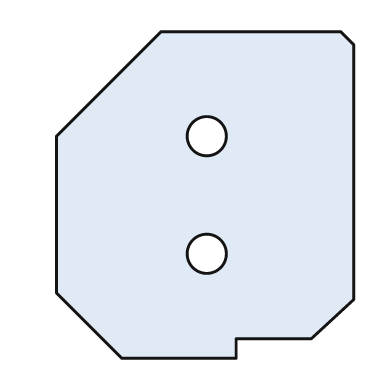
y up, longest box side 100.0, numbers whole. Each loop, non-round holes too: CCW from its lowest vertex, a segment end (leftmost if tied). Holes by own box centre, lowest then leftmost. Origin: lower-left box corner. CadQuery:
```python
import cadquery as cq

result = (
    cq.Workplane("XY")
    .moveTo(20.0, 0.0)
    .lineTo(55.0, 0.0)
    .lineTo(55.0, 6.0)
    .lineTo(78.0, 6.0)
    .lineTo(91.0, 18.0)
    .lineTo(91.0, 96.0)
    .lineTo(87.0, 100.0)
    .lineTo(32.0, 100.0)
    .lineTo(0.0, 68.0)
    .lineTo(0.0, 20.0)
    .close()
    .moveTo(46.0, 32.0)
    .circle(6.0)
    .moveTo(46.0, 68.0)
    .circle(6.0)
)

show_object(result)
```